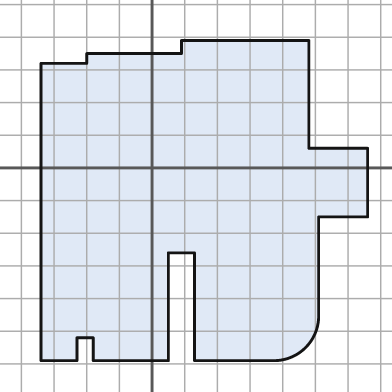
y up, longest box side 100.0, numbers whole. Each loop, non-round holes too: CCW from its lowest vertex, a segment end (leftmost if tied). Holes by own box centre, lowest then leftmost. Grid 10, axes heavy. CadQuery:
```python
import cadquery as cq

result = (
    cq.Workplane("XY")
    .moveTo(-34.0, -59.0)
    .lineTo(-23.0, -59.0)
    .lineTo(-23.0, -52.0)
    .lineTo(-18.0, -52.0)
    .lineTo(-18.0, -59.0)
    .lineTo(5.0, -59.0)
    .lineTo(5.0, -26.0)
    .lineTo(13.0, -26.0)
    .lineTo(13.0, -59.0)
    .lineTo(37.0, -59.0)
    .threePointArc((47.0, -55.0), (51.0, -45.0))
    .lineTo(51.0, -15.0)
    .lineTo(66.0, -15.0)
    .lineTo(66.0, 6.0)
    .lineTo(48.0, 6.0)
    .lineTo(48.0, 39.0)
    .lineTo(9.0, 39.0)
    .lineTo(9.0, 35.0)
    .lineTo(-20.0, 35.0)
    .lineTo(-20.0, 32.0)
    .lineTo(-34.0, 32.0)
    .close()
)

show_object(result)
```